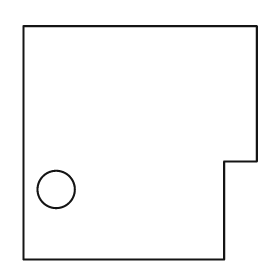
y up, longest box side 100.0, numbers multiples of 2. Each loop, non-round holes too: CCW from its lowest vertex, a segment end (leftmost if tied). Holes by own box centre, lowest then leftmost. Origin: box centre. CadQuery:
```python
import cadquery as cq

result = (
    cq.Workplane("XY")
    .moveTo(-50.0, -50.0)
    .lineTo(36.0, -50.0)
    .lineTo(36.0, -8.0)
    .lineTo(50.0, -8.0)
    .lineTo(50.0, 50.0)
    .lineTo(-50.0, 50.0)
    .close()
    .moveTo(-36.0, -20.0)
    .circle(8.0)
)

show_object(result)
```